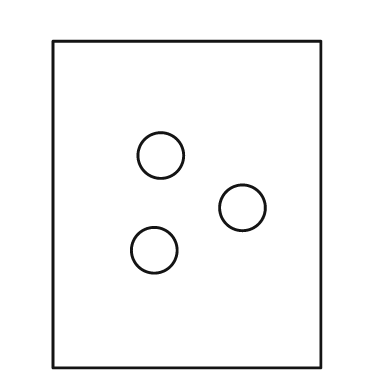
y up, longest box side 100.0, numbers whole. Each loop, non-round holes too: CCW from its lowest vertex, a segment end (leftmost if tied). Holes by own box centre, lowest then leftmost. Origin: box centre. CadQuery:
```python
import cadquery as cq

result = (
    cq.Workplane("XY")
    .moveTo(-41.0, -50.0)
    .lineTo(41.0, -50.0)
    .lineTo(41.0, 50.0)
    .lineTo(-41.0, 50.0)
    .close()
    .moveTo(-10.0, -14.0)
    .circle(7.0)
    .moveTo(17.0, -1.0)
    .circle(7.0)
    .moveTo(-8.0, 15.0)
    .circle(7.0)
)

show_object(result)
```